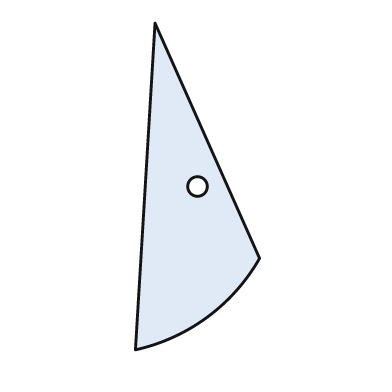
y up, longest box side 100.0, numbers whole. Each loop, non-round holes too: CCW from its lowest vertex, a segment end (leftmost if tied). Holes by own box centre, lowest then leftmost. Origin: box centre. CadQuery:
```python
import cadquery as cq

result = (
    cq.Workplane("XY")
    .moveTo(-19.0, -50.0)
    .threePointArc((3.0, -40.0), (19.0, -22.0))
    .lineTo(-13.0, 50.0)
    .close()
    .moveTo(0.0, 0.0)
    .circle(3.0)
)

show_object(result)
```